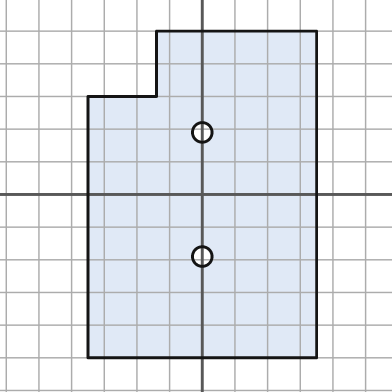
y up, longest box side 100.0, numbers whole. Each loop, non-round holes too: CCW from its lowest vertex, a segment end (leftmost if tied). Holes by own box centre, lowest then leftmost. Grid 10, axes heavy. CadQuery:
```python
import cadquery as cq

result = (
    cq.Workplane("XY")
    .moveTo(-35.0, -50.0)
    .lineTo(35.0, -50.0)
    .lineTo(35.0, 50.0)
    .lineTo(-14.0, 50.0)
    .lineTo(-14.0, 30.0)
    .lineTo(-35.0, 30.0)
    .close()
    .moveTo(0.0, -19.0)
    .circle(3.0)
    .moveTo(0.0, 19.0)
    .circle(3.0)
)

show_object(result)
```